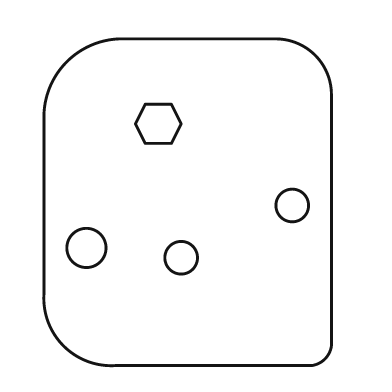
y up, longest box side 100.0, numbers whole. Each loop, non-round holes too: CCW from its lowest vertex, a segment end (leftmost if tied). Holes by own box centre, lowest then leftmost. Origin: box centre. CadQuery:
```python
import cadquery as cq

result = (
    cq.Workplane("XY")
    .moveTo(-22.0, -50.0)
    .lineTo(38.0, -50.0)
    .threePointArc((42.0, -48.0), (44.0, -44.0))
    .lineTo(44.0, 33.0)
    .threePointArc((39.0, 45.0), (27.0, 50.0))
    .lineTo(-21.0, 50.0)
    .threePointArc((-37.0, 43.0), (-44.0, 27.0))
    .lineTo(-44.0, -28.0)
    .threePointArc((-38.0, -44.0), (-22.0, -50.0))
    .close()
    .moveTo(-2.0, -17.0)
    .circle(5.0)
    .moveTo(-31.0, -14.0)
    .circle(6.0)
    .moveTo(32.0, -1.0)
    .circle(5.0)
    .moveTo(-13.0, 18.0)
    .lineTo(-5.0, 18.0)
    .lineTo(-2.0, 24.0)
    .lineTo(-5.0, 30.0)
    .lineTo(-13.0, 30.0)
    .lineTo(-16.0, 24.0)
    .close()
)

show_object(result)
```